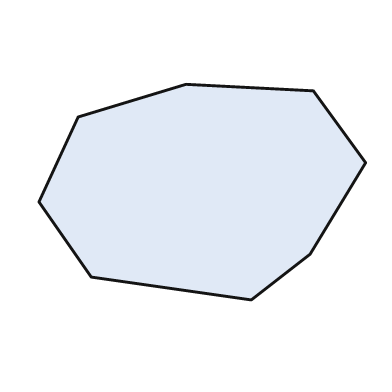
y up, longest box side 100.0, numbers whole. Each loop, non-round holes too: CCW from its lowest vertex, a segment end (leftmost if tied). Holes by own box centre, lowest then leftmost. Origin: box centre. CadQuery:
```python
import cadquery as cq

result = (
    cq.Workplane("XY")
    .moveTo(15.0, -33.0)
    .lineTo(33.0, -19.0)
    .lineTo(50.0, 9.0)
    .lineTo(34.0, 31.0)
    .lineTo(-5.0, 33.0)
    .lineTo(-38.0, 23.0)
    .lineTo(-50.0, -3.0)
    .lineTo(-34.0, -26.0)
    .close()
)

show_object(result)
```